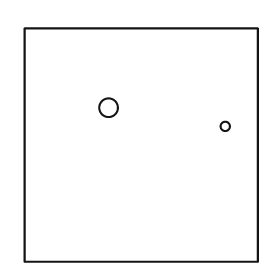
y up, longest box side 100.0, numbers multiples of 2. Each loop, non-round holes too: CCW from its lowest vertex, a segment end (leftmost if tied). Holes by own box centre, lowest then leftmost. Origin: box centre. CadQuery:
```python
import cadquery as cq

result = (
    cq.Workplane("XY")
    .moveTo(-50.0, -50.0)
    .lineTo(50.0, -50.0)
    .lineTo(50.0, 50.0)
    .lineTo(-50.0, 50.0)
    .close()
    .moveTo(36.0, 8.0)
    .circle(2.0)
    .moveTo(-14.0, 16.0)
    .circle(4.0)
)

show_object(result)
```